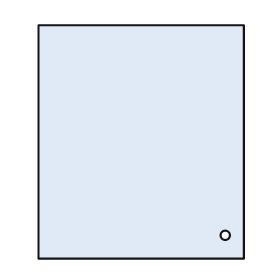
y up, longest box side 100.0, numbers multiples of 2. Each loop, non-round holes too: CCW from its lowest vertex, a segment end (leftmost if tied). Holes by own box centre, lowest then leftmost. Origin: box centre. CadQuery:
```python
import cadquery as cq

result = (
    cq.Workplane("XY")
    .moveTo(-44.0, -50.0)
    .lineTo(44.0, -50.0)
    .lineTo(44.0, 50.0)
    .lineTo(-44.0, 50.0)
    .close()
    .moveTo(36.0, -40.0)
    .circle(2.0)
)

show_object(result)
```